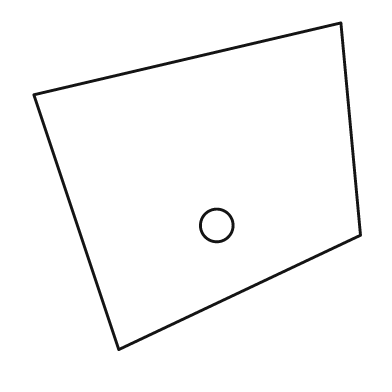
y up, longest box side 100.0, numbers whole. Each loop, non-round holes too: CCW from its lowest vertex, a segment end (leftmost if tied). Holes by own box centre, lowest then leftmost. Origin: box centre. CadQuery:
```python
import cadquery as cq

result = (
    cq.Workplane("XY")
    .moveTo(-24.0, -50.0)
    .lineTo(50.0, -15.0)
    .lineTo(44.0, 50.0)
    .lineTo(-50.0, 28.0)
    .close()
    .moveTo(6.0, -12.0)
    .circle(5.0)
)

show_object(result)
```